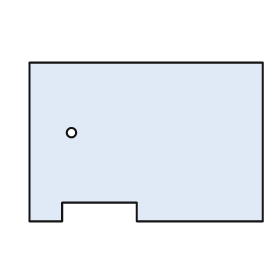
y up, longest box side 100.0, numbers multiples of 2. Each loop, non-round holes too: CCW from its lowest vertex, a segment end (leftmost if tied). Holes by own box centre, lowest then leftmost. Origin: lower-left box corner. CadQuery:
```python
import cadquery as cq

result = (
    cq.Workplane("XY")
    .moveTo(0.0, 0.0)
    .lineTo(14.0, 0.0)
    .lineTo(14.0, 8.0)
    .lineTo(46.0, 8.0)
    .lineTo(46.0, 0.0)
    .lineTo(100.0, 0.0)
    .lineTo(100.0, 68.0)
    .lineTo(0.0, 68.0)
    .close()
    .moveTo(18.0, 38.0)
    .circle(2.0)
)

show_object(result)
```